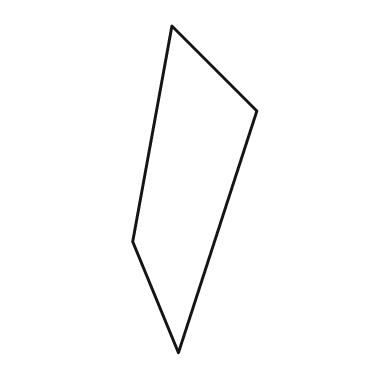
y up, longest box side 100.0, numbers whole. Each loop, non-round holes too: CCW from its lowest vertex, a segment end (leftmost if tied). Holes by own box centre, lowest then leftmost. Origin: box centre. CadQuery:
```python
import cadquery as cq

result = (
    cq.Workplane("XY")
    .moveTo(-5.0, -50.0)
    .lineTo(19.0, 24.0)
    .lineTo(-7.0, 50.0)
    .lineTo(-19.0, -16.0)
    .close()
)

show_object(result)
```